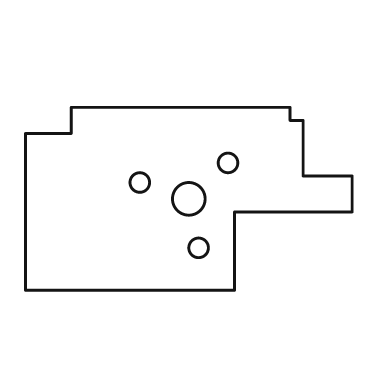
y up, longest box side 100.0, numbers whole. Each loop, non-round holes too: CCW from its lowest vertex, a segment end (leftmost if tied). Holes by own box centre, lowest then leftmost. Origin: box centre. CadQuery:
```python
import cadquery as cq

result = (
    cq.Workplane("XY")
    .moveTo(-50.0, -28.0)
    .lineTo(14.0, -28.0)
    .lineTo(14.0, -4.0)
    .lineTo(50.0, -4.0)
    .lineTo(50.0, 7.0)
    .lineTo(35.0, 7.0)
    .lineTo(35.0, 24.0)
    .lineTo(31.0, 24.0)
    .lineTo(31.0, 28.0)
    .lineTo(-36.0, 28.0)
    .lineTo(-36.0, 20.0)
    .lineTo(-50.0, 20.0)
    .close()
    .moveTo(3.0, -15.0)
    .circle(3.0)
    .moveTo(0.0, 0.0)
    .circle(5.0)
    .moveTo(-15.0, 5.0)
    .circle(3.0)
    .moveTo(12.0, 11.0)
    .circle(3.0)
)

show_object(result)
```